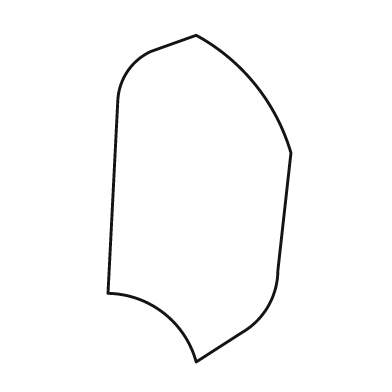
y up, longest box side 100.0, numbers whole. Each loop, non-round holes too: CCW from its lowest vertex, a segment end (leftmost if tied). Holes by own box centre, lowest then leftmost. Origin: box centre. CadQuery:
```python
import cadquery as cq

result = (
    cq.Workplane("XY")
    .moveTo(-1.0, -50.0)
    .lineTo(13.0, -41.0)
    .threePointArc((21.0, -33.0), (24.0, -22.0))
    .lineTo(28.0, 14.0)
    .threePointArc((17.0, 35.0), (-1.0, 50.0))
    .lineTo(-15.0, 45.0)
    .threePointArc((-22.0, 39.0), (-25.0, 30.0))
    .lineTo(-28.0, -29.0)
    .threePointArc((-11.0, -35.0), (-1.0, -50.0))
    .close()
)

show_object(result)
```